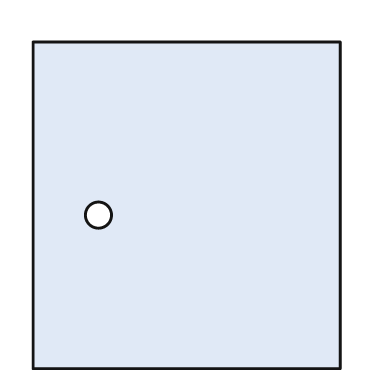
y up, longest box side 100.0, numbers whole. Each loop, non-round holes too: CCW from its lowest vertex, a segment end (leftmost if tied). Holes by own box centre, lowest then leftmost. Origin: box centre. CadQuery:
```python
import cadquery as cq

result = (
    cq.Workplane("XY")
    .moveTo(-47.0, -50.0)
    .lineTo(47.0, -50.0)
    .lineTo(47.0, 50.0)
    .lineTo(-47.0, 50.0)
    .close()
    .moveTo(-27.0, -3.0)
    .circle(4.0)
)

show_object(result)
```